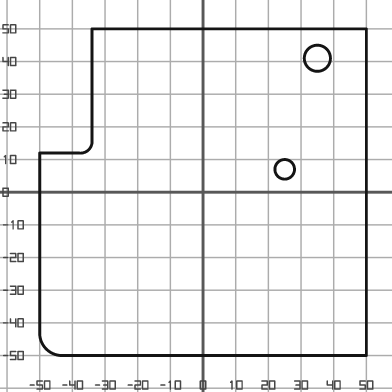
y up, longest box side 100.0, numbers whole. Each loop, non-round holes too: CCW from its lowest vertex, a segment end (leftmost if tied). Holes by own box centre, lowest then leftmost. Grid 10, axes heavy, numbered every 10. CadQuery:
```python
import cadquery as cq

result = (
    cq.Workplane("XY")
    .moveTo(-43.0, -50.0)
    .lineTo(50.0, -50.0)
    .lineTo(50.0, 50.0)
    .lineTo(-34.0, 50.0)
    .lineTo(-34.0, 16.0)
    .threePointArc((-35.0, 13.0), (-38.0, 12.0))
    .lineTo(-50.0, 12.0)
    .lineTo(-50.0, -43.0)
    .threePointArc((-48.0, -48.0), (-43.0, -50.0))
    .close()
    .moveTo(25.0, 7.0)
    .circle(3.0)
    .moveTo(35.0, 41.0)
    .circle(4.0)
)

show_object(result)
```